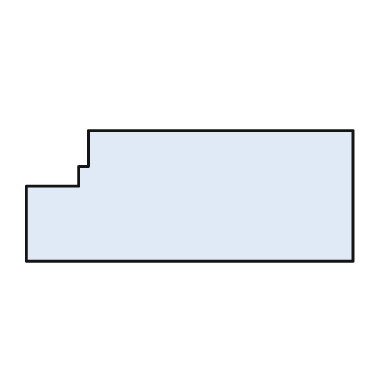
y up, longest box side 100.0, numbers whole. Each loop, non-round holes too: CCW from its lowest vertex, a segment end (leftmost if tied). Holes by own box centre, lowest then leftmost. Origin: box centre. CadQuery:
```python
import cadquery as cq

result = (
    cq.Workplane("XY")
    .moveTo(-50.0, -20.0)
    .lineTo(50.0, -20.0)
    .lineTo(50.0, 20.0)
    .lineTo(-31.0, 20.0)
    .lineTo(-31.0, 9.0)
    .lineTo(-34.0, 9.0)
    .lineTo(-34.0, 3.0)
    .lineTo(-50.0, 3.0)
    .close()
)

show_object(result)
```